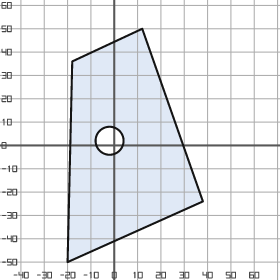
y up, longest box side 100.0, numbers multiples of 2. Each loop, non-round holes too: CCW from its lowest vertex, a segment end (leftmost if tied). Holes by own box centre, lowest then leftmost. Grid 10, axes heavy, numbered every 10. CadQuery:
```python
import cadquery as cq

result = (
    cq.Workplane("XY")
    .moveTo(-20.0, -50.0)
    .lineTo(38.0, -24.0)
    .lineTo(12.0, 50.0)
    .lineTo(-18.0, 36.0)
    .close()
    .moveTo(-2.0, 2.0)
    .circle(6.0)
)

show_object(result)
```